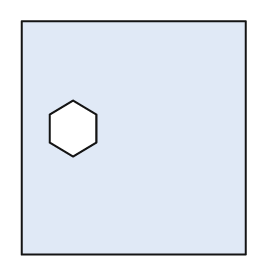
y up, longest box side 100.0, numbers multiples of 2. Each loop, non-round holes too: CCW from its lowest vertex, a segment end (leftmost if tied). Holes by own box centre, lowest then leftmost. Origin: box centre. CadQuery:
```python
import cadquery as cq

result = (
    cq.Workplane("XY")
    .moveTo(-48.0, -50.0)
    .lineTo(48.0, -50.0)
    .lineTo(48.0, 50.0)
    .lineTo(-48.0, 50.0)
    .close()
    .moveTo(-26.0, -8.0)
    .lineTo(-16.0, -2.0)
    .lineTo(-16.0, 10.0)
    .lineTo(-26.0, 16.0)
    .lineTo(-36.0, 10.0)
    .lineTo(-36.0, -2.0)
    .close()
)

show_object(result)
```